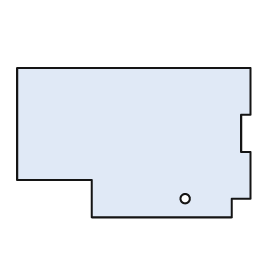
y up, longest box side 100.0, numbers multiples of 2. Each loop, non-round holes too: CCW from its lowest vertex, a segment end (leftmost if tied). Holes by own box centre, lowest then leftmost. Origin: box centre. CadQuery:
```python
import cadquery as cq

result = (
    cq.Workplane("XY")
    .moveTo(-18.0, -32.0)
    .lineTo(42.0, -32.0)
    .lineTo(42.0, -24.0)
    .lineTo(50.0, -24.0)
    .lineTo(50.0, -4.0)
    .lineTo(46.0, -4.0)
    .lineTo(46.0, 12.0)
    .lineTo(50.0, 12.0)
    .lineTo(50.0, 32.0)
    .lineTo(-50.0, 32.0)
    .lineTo(-50.0, -16.0)
    .lineTo(-18.0, -16.0)
    .close()
    .moveTo(22.0, -24.0)
    .circle(2.0)
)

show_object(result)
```